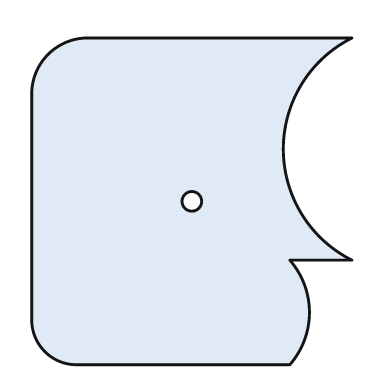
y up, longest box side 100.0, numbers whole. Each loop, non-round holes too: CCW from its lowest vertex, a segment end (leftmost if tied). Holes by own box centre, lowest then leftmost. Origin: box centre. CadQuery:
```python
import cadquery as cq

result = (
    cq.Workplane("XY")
    .moveTo(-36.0, -50.0)
    .lineTo(30.0, -50.0)
    .threePointArc((36.0, -34.0), (30.0, -18.0))
    .lineTo(49.0, -18.0)
    .threePointArc((28.0, 16.0), (49.0, 50.0))
    .lineTo(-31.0, 50.0)
    .threePointArc((-44.0, 45.0), (-49.0, 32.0))
    .lineTo(-49.0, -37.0)
    .threePointArc((-45.0, -46.0), (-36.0, -50.0))
    .close()
    .moveTo(0.0, 0.0)
    .circle(3.0)
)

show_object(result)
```